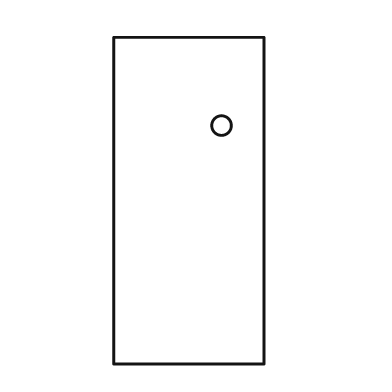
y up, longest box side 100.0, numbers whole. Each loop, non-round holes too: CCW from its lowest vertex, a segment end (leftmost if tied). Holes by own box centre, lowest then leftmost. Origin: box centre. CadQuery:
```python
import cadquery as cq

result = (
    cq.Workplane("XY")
    .moveTo(-23.0, -50.0)
    .lineTo(23.0, -50.0)
    .lineTo(23.0, 50.0)
    .lineTo(-23.0, 50.0)
    .close()
    .moveTo(10.0, 23.0)
    .circle(3.0)
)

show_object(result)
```